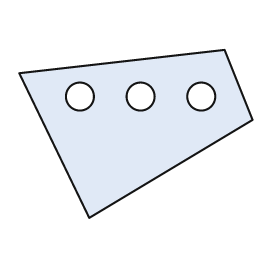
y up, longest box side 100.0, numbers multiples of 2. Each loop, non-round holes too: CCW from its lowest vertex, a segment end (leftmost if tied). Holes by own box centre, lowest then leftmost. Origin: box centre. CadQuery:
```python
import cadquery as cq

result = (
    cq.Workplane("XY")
    .moveTo(-20.0, -36.0)
    .lineTo(50.0, 6.0)
    .lineTo(38.0, 36.0)
    .lineTo(-50.0, 26.0)
    .close()
    .moveTo(-24.0, 16.0)
    .circle(6.0)
    .moveTo(2.0, 16.0)
    .circle(6.0)
    .moveTo(28.0, 16.0)
    .circle(6.0)
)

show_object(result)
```